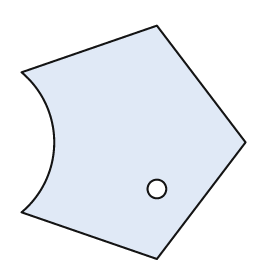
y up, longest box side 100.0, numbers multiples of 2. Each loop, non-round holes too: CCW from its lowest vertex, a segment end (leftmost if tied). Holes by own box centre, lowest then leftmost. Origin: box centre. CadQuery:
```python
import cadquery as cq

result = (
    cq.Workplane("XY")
    .moveTo(10.0, -50.0)
    .lineTo(48.0, 0.0)
    .lineTo(10.0, 50.0)
    .lineTo(-48.0, 30.0)
    .threePointArc((-34.0, 0.0), (-48.0, -30.0))
    .close()
    .moveTo(10.0, -20.0)
    .circle(4.0)
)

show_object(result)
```